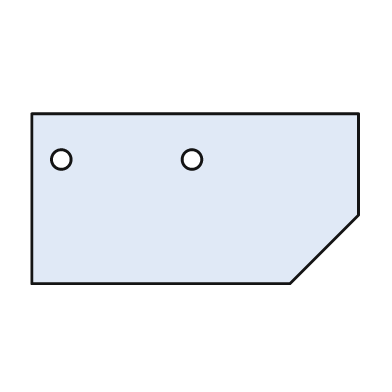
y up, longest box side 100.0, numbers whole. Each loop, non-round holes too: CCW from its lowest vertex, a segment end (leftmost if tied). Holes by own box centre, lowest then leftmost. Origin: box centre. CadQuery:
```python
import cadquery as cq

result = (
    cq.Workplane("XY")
    .moveTo(-50.0, -26.0)
    .lineTo(29.0, -26.0)
    .lineTo(50.0, -5.0)
    .lineTo(50.0, 26.0)
    .lineTo(-50.0, 26.0)
    .close()
    .moveTo(-41.0, 12.0)
    .circle(3.0)
    .moveTo(-1.0, 12.0)
    .circle(3.0)
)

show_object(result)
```